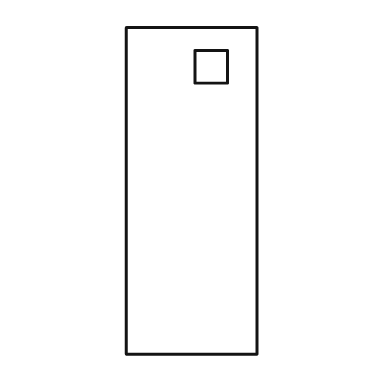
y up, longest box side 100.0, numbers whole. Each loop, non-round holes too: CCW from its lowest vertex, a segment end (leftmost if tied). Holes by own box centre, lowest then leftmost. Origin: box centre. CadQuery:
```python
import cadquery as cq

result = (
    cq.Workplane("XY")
    .moveTo(-20.0, -50.0)
    .lineTo(20.0, -50.0)
    .lineTo(20.0, 50.0)
    .lineTo(-20.0, 50.0)
    .close()
    .moveTo(1.0, 33.0)
    .lineTo(11.0, 33.0)
    .lineTo(11.0, 43.0)
    .lineTo(1.0, 43.0)
    .close()
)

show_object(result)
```